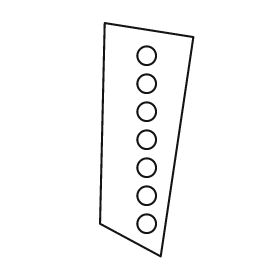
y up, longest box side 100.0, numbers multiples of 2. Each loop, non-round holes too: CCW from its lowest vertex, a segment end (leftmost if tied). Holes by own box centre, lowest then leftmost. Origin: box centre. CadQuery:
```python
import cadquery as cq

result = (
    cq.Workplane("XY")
    .moveTo(6.0, -50.0)
    .lineTo(20.0, 44.0)
    .lineTo(-18.0, 50.0)
    .lineTo(-20.0, -36.0)
    .close()
    .moveTo(0.0, -36.0)
    .circle(4.0)
    .moveTo(0.0, -24.0)
    .circle(4.0)
    .moveTo(0.0, -12.0)
    .circle(4.0)
    .moveTo(0.0, 0.0)
    .circle(4.0)
    .moveTo(0.0, 12.0)
    .circle(4.0)
    .moveTo(0.0, 24.0)
    .circle(4.0)
    .moveTo(0.0, 36.0)
    .circle(4.0)
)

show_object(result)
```